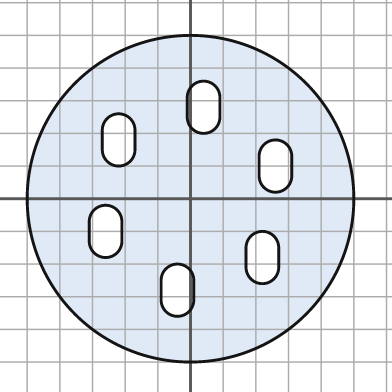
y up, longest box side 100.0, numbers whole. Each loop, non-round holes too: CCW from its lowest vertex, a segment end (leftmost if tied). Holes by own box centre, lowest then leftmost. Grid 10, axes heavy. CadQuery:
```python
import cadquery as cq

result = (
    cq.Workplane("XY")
    .moveTo(0.0, 0.0)
    .circle(50.0)
    .moveTo(-9.0, -31.0)
    .threePointArc((-4.0, -36.0), (1.0, -31.0))
    .lineTo(1.0, -25.0)
    .threePointArc((-4.0, -20.0), (-9.0, -25.0))
    .close()
    .moveTo(17.0, -21.0)
    .threePointArc((22.0, -26.0), (27.0, -21.0))
    .lineTo(27.0, -15.0)
    .threePointArc((22.0, -10.0), (17.0, -15.0))
    .close()
    .moveTo(-31.0, -13.0)
    .threePointArc((-26.0, -18.0), (-21.0, -13.0))
    .lineTo(-21.0, -7.0)
    .threePointArc((-26.0, -2.0), (-31.0, -7.0))
    .close()
    .moveTo(21.0, 7.0)
    .threePointArc((26.0, 2.0), (31.0, 7.0))
    .lineTo(31.0, 13.0)
    .threePointArc((26.0, 18.0), (21.0, 13.0))
    .close()
    .moveTo(-27.0, 15.0)
    .threePointArc((-22.0, 10.0), (-17.0, 15.0))
    .lineTo(-17.0, 21.0)
    .threePointArc((-22.0, 26.0), (-27.0, 21.0))
    .close()
    .moveTo(-1.0, 25.0)
    .threePointArc((4.0, 20.0), (9.0, 25.0))
    .lineTo(9.0, 31.0)
    .threePointArc((4.0, 36.0), (-1.0, 31.0))
    .close()
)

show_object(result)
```